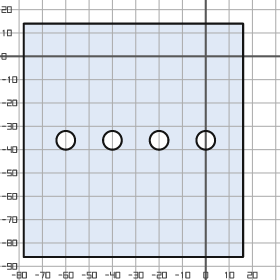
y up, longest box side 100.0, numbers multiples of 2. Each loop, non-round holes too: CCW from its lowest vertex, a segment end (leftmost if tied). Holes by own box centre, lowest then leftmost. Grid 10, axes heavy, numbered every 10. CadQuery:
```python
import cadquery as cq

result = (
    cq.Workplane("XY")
    .moveTo(-78.0, -86.0)
    .lineTo(16.0, -86.0)
    .lineTo(16.0, 14.0)
    .lineTo(-78.0, 14.0)
    .close()
    .moveTo(-60.0, -36.0)
    .circle(4.0)
    .moveTo(-40.0, -36.0)
    .circle(4.0)
    .moveTo(-20.0, -36.0)
    .circle(4.0)
    .moveTo(0.0, -36.0)
    .circle(4.0)
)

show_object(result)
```